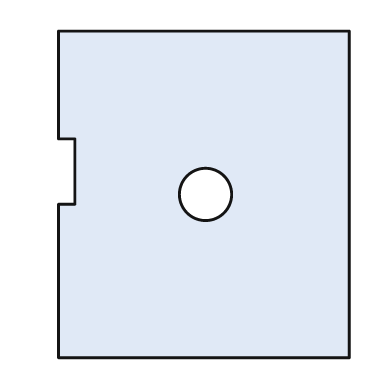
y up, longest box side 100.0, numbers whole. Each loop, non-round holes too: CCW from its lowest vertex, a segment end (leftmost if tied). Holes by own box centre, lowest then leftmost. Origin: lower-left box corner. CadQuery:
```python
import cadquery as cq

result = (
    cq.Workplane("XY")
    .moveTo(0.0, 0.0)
    .lineTo(89.0, 0.0)
    .lineTo(89.0, 100.0)
    .lineTo(0.0, 100.0)
    .lineTo(0.0, 67.0)
    .lineTo(5.0, 67.0)
    .lineTo(5.0, 47.0)
    .lineTo(0.0, 47.0)
    .close()
    .moveTo(45.0, 50.0)
    .circle(8.0)
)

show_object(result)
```